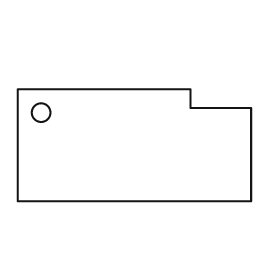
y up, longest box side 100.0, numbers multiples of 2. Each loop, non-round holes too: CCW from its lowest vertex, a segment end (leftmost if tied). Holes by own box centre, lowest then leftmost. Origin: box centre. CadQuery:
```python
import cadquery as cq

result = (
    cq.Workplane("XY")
    .moveTo(-50.0, -24.0)
    .lineTo(50.0, -24.0)
    .lineTo(50.0, 16.0)
    .lineTo(24.0, 16.0)
    .lineTo(24.0, 24.0)
    .lineTo(-50.0, 24.0)
    .close()
    .moveTo(-40.0, 14.0)
    .circle(4.0)
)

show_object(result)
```